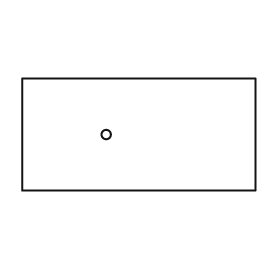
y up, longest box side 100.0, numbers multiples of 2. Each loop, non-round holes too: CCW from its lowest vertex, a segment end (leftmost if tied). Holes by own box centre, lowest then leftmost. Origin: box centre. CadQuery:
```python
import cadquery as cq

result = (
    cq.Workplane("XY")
    .moveTo(-50.0, -24.0)
    .lineTo(50.0, -24.0)
    .lineTo(50.0, 24.0)
    .lineTo(-50.0, 24.0)
    .close()
    .moveTo(-14.0, 0.0)
    .circle(2.0)
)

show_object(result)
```